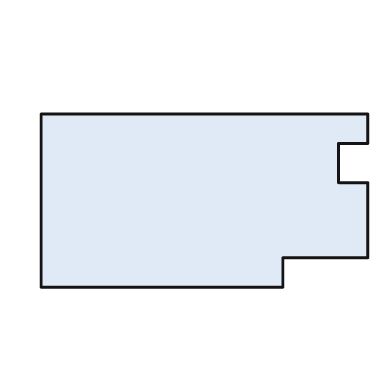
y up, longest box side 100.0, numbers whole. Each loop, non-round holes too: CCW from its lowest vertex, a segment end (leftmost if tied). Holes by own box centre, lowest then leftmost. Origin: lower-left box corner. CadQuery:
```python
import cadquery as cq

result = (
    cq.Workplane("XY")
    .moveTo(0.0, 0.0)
    .lineTo(74.0, 0.0)
    .lineTo(74.0, 9.0)
    .lineTo(100.0, 9.0)
    .lineTo(100.0, 32.0)
    .lineTo(91.0, 32.0)
    .lineTo(91.0, 44.0)
    .lineTo(100.0, 44.0)
    .lineTo(100.0, 53.0)
    .lineTo(0.0, 53.0)
    .close()
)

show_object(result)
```